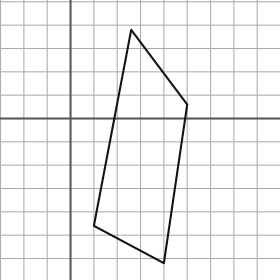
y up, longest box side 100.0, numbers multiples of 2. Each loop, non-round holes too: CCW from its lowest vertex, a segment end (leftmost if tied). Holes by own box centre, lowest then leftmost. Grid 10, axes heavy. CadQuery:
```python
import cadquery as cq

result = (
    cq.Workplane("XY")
    .moveTo(40.0, -62.0)
    .lineTo(50.0, 6.0)
    .lineTo(26.0, 38.0)
    .lineTo(10.0, -46.0)
    .close()
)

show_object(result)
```